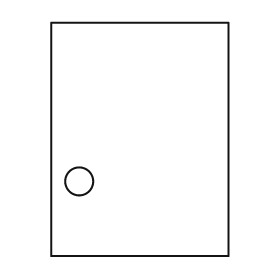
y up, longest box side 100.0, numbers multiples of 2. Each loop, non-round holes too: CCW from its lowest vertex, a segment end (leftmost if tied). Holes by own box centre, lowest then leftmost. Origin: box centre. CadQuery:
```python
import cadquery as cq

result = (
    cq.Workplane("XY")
    .moveTo(-38.0, -50.0)
    .lineTo(38.0, -50.0)
    .lineTo(38.0, 50.0)
    .lineTo(-38.0, 50.0)
    .close()
    .moveTo(-26.0, -18.0)
    .circle(6.0)
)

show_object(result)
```